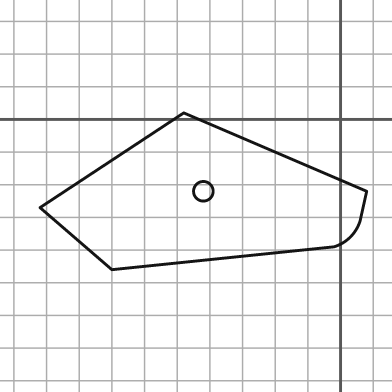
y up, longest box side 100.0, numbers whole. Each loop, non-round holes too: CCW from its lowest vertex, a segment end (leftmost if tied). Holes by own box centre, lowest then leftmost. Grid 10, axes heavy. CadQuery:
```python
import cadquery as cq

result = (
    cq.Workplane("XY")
    .moveTo(-70.0, -46.0)
    .lineTo(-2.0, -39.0)
    .threePointArc((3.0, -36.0), (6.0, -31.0))
    .lineTo(8.0, -22.0)
    .lineTo(-48.0, 2.0)
    .lineTo(-92.0, -27.0)
    .close()
    .moveTo(-42.0, -22.0)
    .circle(3.0)
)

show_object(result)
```